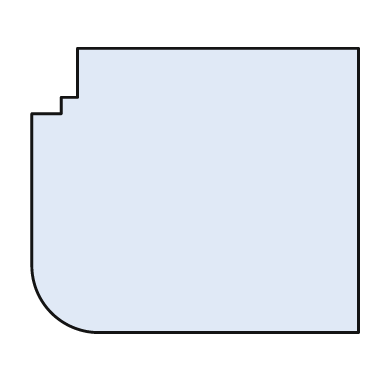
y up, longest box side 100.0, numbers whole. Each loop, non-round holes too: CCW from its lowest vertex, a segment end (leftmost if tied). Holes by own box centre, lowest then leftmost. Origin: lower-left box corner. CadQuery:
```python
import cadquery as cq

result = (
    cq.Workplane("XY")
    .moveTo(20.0, 0.0)
    .lineTo(100.0, 0.0)
    .lineTo(100.0, 87.0)
    .lineTo(14.0, 87.0)
    .lineTo(14.0, 72.0)
    .lineTo(9.0, 72.0)
    .lineTo(9.0, 67.0)
    .lineTo(0.0, 67.0)
    .lineTo(0.0, 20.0)
    .threePointArc((6.0, 6.0), (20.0, 0.0))
    .close()
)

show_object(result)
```